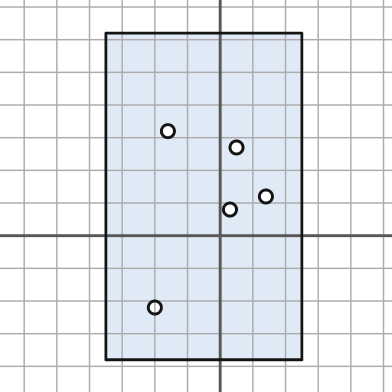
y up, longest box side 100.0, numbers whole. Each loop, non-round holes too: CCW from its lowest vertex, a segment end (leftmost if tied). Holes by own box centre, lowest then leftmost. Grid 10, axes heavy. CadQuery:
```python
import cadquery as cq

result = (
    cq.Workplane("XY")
    .moveTo(-35.0, -38.0)
    .lineTo(25.0, -38.0)
    .lineTo(25.0, 62.0)
    .lineTo(-35.0, 62.0)
    .close()
    .moveTo(-20.0, -22.0)
    .circle(2.0)
    .moveTo(3.0, 8.0)
    .circle(2.0)
    .moveTo(14.0, 12.0)
    .circle(2.0)
    .moveTo(5.0, 27.0)
    .circle(2.0)
    .moveTo(-16.0, 32.0)
    .circle(2.0)
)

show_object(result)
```